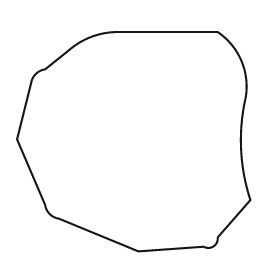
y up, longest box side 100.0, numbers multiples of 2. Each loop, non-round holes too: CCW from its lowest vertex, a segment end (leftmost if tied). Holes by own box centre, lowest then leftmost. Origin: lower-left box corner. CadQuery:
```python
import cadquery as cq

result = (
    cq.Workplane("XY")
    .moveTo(52.0, 0.0)
    .lineTo(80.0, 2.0)
    .threePointArc((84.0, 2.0), (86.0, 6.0))
    .lineTo(100.0, 22.0)
    .threePointArc((96.0, 44.0), (98.0, 66.0))
    .threePointArc((96.0, 82.0), (86.0, 94.0))
    .lineTo(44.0, 94.0)
    .threePointArc((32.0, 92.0), (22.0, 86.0))
    .lineTo(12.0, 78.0)
    .threePointArc((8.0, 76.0), (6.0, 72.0))
    .lineTo(0.0, 48.0)
    .lineTo(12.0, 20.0)
    .threePointArc((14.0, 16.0), (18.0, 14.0))
    .close()
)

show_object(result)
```